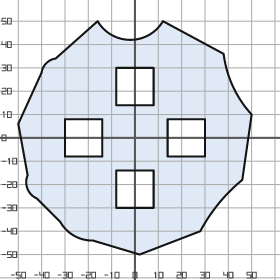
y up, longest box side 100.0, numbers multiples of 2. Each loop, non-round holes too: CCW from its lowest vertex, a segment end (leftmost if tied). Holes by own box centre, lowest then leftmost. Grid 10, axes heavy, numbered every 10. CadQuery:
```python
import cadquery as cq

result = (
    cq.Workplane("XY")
    .moveTo(2.0, -50.0)
    .lineTo(28.0, -40.0)
    .threePointArc((36.0, -28.0), (46.0, -18.0))
    .lineTo(50.0, 10.0)
    .threePointArc((42.0, 22.0), (38.0, 36.0))
    .lineTo(12.0, 50.0)
    .threePointArc((-2.0, 42.0), (-16.0, 50.0))
    .lineTo(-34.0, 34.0)
    .threePointArc((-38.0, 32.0), (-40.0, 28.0))
    .lineTo(-50.0, 6.0)
    .lineTo(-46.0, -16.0)
    .threePointArc((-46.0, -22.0), (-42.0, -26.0))
    .lineTo(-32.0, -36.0)
    .threePointArc((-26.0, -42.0), (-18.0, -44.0))
    .close()
    .moveTo(-8.0, -30.0)
    .lineTo(8.0, -30.0)
    .lineTo(8.0, -14.0)
    .lineTo(-8.0, -14.0)
    .close()
    .moveTo(-30.0, -8.0)
    .lineTo(-14.0, -8.0)
    .lineTo(-14.0, 8.0)
    .lineTo(-30.0, 8.0)
    .close()
    .moveTo(14.0, -8.0)
    .lineTo(30.0, -8.0)
    .lineTo(30.0, 8.0)
    .lineTo(14.0, 8.0)
    .close()
    .moveTo(-8.0, 14.0)
    .lineTo(8.0, 14.0)
    .lineTo(8.0, 30.0)
    .lineTo(-8.0, 30.0)
    .close()
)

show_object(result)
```